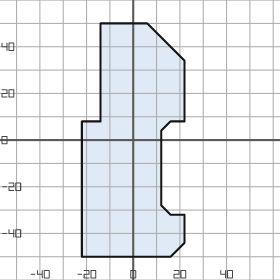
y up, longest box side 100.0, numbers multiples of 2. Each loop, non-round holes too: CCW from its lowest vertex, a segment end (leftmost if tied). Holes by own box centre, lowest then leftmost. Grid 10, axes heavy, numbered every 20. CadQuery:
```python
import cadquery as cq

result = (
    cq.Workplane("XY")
    .moveTo(-22.0, -50.0)
    .lineTo(16.0, -50.0)
    .lineTo(22.0, -44.0)
    .lineTo(22.0, -32.0)
    .lineTo(16.0, -32.0)
    .lineTo(12.0, -28.0)
    .lineTo(12.0, 4.0)
    .lineTo(16.0, 8.0)
    .lineTo(22.0, 8.0)
    .lineTo(22.0, 34.0)
    .lineTo(6.0, 50.0)
    .lineTo(-14.0, 50.0)
    .lineTo(-14.0, 8.0)
    .lineTo(-22.0, 8.0)
    .close()
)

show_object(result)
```